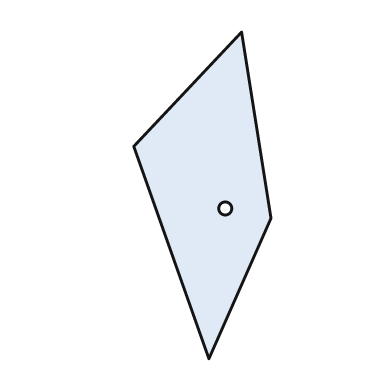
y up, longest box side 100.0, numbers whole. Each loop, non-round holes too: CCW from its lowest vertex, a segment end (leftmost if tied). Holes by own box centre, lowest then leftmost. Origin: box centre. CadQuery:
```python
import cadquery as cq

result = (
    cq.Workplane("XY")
    .moveTo(2.0, -50.0)
    .lineTo(21.0, -7.0)
    .lineTo(12.0, 50.0)
    .lineTo(-21.0, 15.0)
    .close()
    .moveTo(7.0, -4.0)
    .circle(2.0)
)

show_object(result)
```